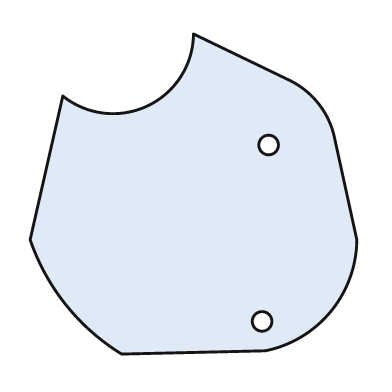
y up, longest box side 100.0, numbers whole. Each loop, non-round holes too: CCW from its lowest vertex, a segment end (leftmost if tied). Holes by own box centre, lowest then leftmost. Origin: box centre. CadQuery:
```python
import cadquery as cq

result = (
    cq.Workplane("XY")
    .moveTo(-22.0, -49.0)
    .lineTo(22.0, -48.0)
    .threePointArc((42.0, -36.0), (50.0, -14.0))
    .lineTo(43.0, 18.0)
    .threePointArc((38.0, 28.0), (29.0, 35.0))
    .lineTo(0.0, 49.0)
    .threePointArc((-14.0, 27.0), (-40.0, 30.0))
    .lineTo(-50.0, -14.0)
    .threePointArc((-39.0, -34.0), (-22.0, -49.0))
    .close()
    .moveTo(21.0, -39.0)
    .circle(3.0)
    .moveTo(23.0, 15.0)
    .circle(3.0)
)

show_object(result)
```